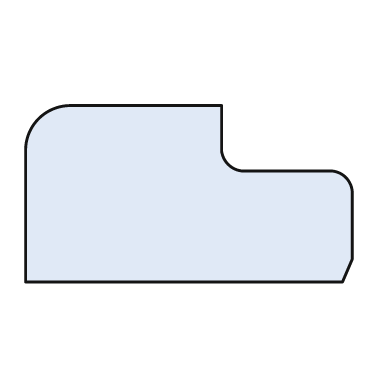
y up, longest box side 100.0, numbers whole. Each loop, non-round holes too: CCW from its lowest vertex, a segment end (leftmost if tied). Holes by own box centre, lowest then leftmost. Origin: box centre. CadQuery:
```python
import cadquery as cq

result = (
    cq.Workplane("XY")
    .moveTo(-50.0, -27.0)
    .lineTo(47.0, -27.0)
    .lineTo(50.0, -20.0)
    .lineTo(50.0, 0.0)
    .threePointArc((48.0, 5.0), (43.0, 7.0))
    .lineTo(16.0, 7.0)
    .threePointArc((12.0, 9.0), (10.0, 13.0))
    .lineTo(10.0, 27.0)
    .lineTo(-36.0, 27.0)
    .threePointArc((-46.0, 23.0), (-50.0, 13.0))
    .close()
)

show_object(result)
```